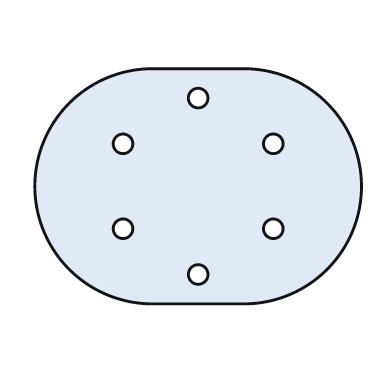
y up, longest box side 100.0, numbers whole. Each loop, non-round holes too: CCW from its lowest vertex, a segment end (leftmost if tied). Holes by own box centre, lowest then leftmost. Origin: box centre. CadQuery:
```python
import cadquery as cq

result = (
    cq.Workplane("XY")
    .moveTo(-14.0, -36.0)
    .lineTo(14.0, -36.0)
    .threePointArc((50.0, 0.0), (14.0, 36.0))
    .lineTo(-14.0, 36.0)
    .threePointArc((-50.0, 0.0), (-14.0, -36.0))
    .close()
    .moveTo(0.0, -27.0)
    .circle(3.0)
    .moveTo(-23.0, -13.0)
    .circle(3.0)
    .moveTo(23.0, -13.0)
    .circle(3.0)
    .moveTo(-23.0, 13.0)
    .circle(3.0)
    .moveTo(23.0, 13.0)
    .circle(3.0)
    .moveTo(0.0, 27.0)
    .circle(3.0)
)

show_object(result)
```